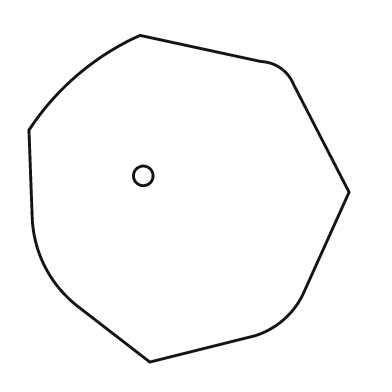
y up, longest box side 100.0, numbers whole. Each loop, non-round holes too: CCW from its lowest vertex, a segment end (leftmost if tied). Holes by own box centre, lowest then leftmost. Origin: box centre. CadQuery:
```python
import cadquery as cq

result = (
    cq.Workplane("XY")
    .moveTo(-12.0, -50.0)
    .lineTo(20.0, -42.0)
    .threePointArc((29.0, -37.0), (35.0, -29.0))
    .lineTo(49.0, 2.0)
    .lineTo(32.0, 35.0)
    .threePointArc((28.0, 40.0), (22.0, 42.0))
    .lineTo(-15.0, 50.0)
    .threePointArc((-34.0, 38.0), (-49.0, 21.0))
    .lineTo(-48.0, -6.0)
    .threePointArc((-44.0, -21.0), (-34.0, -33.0))
    .close()
    .moveTo(-14.0, 7.0)
    .circle(3.0)
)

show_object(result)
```